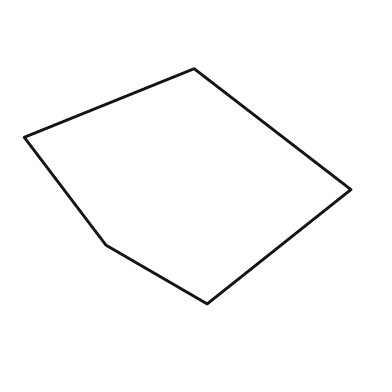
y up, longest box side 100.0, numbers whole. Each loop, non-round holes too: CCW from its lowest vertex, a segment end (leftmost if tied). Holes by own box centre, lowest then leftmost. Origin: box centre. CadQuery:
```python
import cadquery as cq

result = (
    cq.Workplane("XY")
    .moveTo(6.0, -36.0)
    .lineTo(50.0, -1.0)
    .lineTo(2.0, 36.0)
    .lineTo(-50.0, 15.0)
    .lineTo(-25.0, -18.0)
    .close()
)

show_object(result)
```